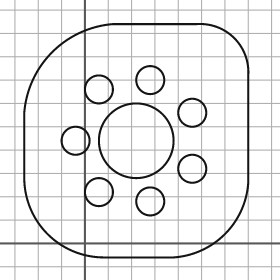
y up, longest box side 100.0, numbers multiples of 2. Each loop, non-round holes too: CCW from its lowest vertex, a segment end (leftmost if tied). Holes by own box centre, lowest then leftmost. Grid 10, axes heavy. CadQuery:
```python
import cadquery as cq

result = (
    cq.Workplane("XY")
    .moveTo(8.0, -6.0)
    .lineTo(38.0, -6.0)
    .threePointArc((60.0, 4.0), (70.0, 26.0))
    .lineTo(70.0, 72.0)
    .threePointArc((64.0, 88.0), (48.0, 94.0))
    .lineTo(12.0, 94.0)
    .threePointArc((-14.0, 82.0), (-26.0, 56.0))
    .lineTo(-26.0, 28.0)
    .threePointArc((-16.0, 4.0), (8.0, -6.0))
    .close()
    .moveTo(28.0, 18.0)
    .circle(6.0)
    .moveTo(6.0, 22.0)
    .circle(6.0)
    .moveTo(46.0, 32.0)
    .circle(6.0)
    .moveTo(-4.0, 44.0)
    .circle(6.0)
    .moveTo(22.0, 44.0)
    .circle(16.0)
    .moveTo(46.0, 56.0)
    .circle(6.0)
    .moveTo(6.0, 66.0)
    .circle(6.0)
    .moveTo(28.0, 70.0)
    .circle(6.0)
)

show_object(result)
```